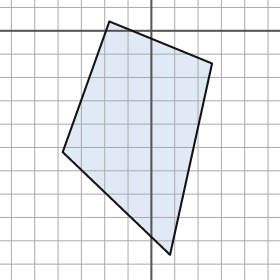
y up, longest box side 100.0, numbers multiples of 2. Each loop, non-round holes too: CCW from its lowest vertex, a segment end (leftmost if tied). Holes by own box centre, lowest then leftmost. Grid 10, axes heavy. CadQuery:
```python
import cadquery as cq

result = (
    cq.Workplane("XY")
    .moveTo(8.0, -96.0)
    .lineTo(26.0, -14.0)
    .lineTo(-18.0, 4.0)
    .lineTo(-38.0, -52.0)
    .close()
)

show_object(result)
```